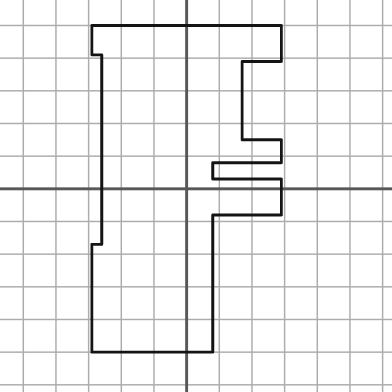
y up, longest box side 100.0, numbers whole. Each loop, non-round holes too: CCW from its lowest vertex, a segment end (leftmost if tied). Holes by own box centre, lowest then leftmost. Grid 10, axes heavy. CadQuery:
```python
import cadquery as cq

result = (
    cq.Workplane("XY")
    .moveTo(-29.0, -50.0)
    .lineTo(8.0, -50.0)
    .lineTo(8.0, -8.0)
    .lineTo(29.0, -8.0)
    .lineTo(29.0, 3.0)
    .lineTo(8.0, 3.0)
    .lineTo(8.0, 8.0)
    .lineTo(29.0, 8.0)
    .lineTo(29.0, 15.0)
    .lineTo(17.0, 15.0)
    .lineTo(17.0, 39.0)
    .lineTo(29.0, 39.0)
    .lineTo(29.0, 50.0)
    .lineTo(-29.0, 50.0)
    .lineTo(-29.0, 41.0)
    .lineTo(-26.0, 41.0)
    .lineTo(-26.0, -17.0)
    .lineTo(-29.0, -17.0)
    .close()
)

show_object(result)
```